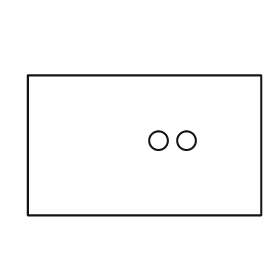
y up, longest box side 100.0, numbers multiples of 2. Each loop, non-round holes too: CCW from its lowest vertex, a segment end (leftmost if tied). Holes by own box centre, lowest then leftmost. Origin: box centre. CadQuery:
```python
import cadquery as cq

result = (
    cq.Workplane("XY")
    .moveTo(-50.0, -30.0)
    .lineTo(50.0, -30.0)
    .lineTo(50.0, 30.0)
    .lineTo(-50.0, 30.0)
    .close()
    .moveTo(6.0, 2.0)
    .circle(4.0)
    .moveTo(18.0, 2.0)
    .circle(4.0)
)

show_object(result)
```